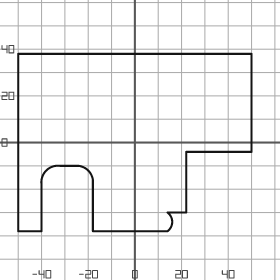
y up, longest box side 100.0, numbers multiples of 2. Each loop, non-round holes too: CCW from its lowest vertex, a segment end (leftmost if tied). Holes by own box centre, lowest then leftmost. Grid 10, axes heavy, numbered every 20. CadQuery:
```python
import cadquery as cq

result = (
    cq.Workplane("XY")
    .moveTo(-50.0, -38.0)
    .lineTo(-40.0, -38.0)
    .lineTo(-40.0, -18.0)
    .threePointArc((-38.0, -12.0), (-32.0, -10.0))
    .lineTo(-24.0, -10.0)
    .threePointArc((-20.0, -12.0), (-18.0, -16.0))
    .lineTo(-18.0, -38.0)
    .lineTo(14.0, -38.0)
    .threePointArc((16.0, -34.0), (14.0, -30.0))
    .lineTo(22.0, -30.0)
    .lineTo(22.0, -4.0)
    .lineTo(50.0, -4.0)
    .lineTo(50.0, 38.0)
    .lineTo(-50.0, 38.0)
    .close()
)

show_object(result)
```